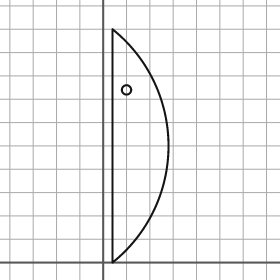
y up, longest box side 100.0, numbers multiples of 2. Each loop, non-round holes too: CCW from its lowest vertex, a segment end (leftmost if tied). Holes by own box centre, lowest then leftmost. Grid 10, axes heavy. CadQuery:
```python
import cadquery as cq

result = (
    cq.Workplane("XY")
    .moveTo(4.0, 0.0)
    .threePointArc((28.0, 50.0), (4.0, 100.0))
    .close()
    .moveTo(10.0, 74.0)
    .circle(2.0)
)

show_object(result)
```